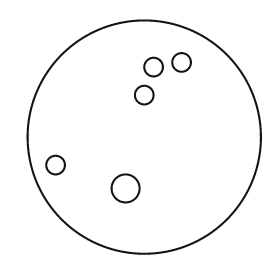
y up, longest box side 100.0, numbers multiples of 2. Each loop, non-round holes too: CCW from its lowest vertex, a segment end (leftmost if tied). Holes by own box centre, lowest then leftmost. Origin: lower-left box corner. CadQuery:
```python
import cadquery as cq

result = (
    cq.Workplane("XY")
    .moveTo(50.0, 50.0)
    .circle(50.0)
    .moveTo(42.0, 28.0)
    .circle(6.0)
    .moveTo(12.0, 38.0)
    .circle(4.0)
    .moveTo(50.0, 68.0)
    .circle(4.0)
    .moveTo(54.0, 80.0)
    .circle(4.0)
    .moveTo(66.0, 82.0)
    .circle(4.0)
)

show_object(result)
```